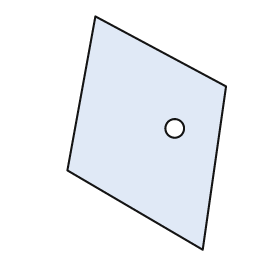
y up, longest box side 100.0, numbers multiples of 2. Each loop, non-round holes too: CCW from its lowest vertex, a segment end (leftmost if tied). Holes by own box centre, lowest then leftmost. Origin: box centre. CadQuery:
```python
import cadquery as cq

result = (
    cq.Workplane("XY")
    .moveTo(24.0, -50.0)
    .lineTo(34.0, 20.0)
    .lineTo(-22.0, 50.0)
    .lineTo(-34.0, -16.0)
    .close()
    .moveTo(12.0, 2.0)
    .circle(4.0)
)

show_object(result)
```